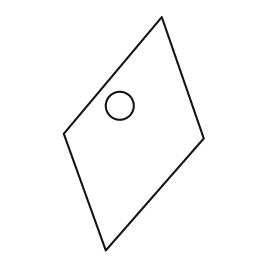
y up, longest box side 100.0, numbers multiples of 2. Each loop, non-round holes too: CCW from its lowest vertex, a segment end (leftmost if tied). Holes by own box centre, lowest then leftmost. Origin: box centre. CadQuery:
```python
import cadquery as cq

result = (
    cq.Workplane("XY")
    .moveTo(-12.0, -50.0)
    .lineTo(30.0, -2.0)
    .lineTo(12.0, 50.0)
    .lineTo(-30.0, 0.0)
    .close()
    .moveTo(-6.0, 12.0)
    .circle(6.0)
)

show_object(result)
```